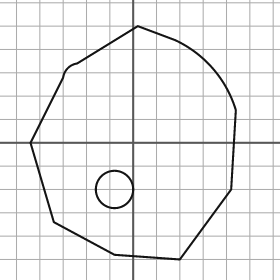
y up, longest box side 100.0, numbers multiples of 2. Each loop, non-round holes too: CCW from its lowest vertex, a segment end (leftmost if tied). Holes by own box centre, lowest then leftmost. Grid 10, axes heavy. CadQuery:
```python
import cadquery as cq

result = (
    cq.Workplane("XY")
    .moveTo(20.0, -50.0)
    .lineTo(42.0, -20.0)
    .lineTo(44.0, 14.0)
    .threePointArc((34.0, 32.0), (18.0, 44.0))
    .lineTo(2.0, 50.0)
    .lineTo(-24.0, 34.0)
    .threePointArc((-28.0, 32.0), (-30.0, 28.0))
    .lineTo(-44.0, 0.0)
    .lineTo(-34.0, -34.0)
    .lineTo(-8.0, -48.0)
    .close()
    .moveTo(-8.0, -20.0)
    .circle(8.0)
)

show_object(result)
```